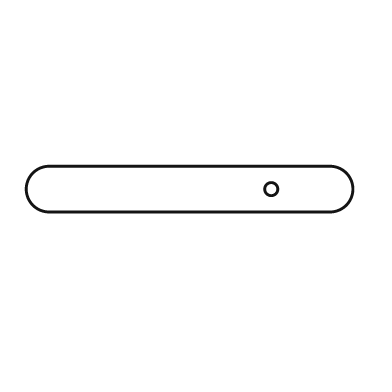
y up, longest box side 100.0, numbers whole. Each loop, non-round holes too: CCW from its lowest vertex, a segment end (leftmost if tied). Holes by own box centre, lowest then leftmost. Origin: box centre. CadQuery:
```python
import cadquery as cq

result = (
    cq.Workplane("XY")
    .moveTo(-43.0, -7.0)
    .lineTo(43.0, -7.0)
    .threePointArc((50.0, 0.0), (43.0, 7.0))
    .lineTo(-43.0, 7.0)
    .threePointArc((-50.0, 0.0), (-43.0, -7.0))
    .close()
    .moveTo(25.0, 0.0)
    .circle(2.0)
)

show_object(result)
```